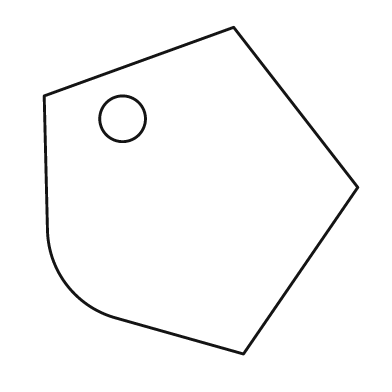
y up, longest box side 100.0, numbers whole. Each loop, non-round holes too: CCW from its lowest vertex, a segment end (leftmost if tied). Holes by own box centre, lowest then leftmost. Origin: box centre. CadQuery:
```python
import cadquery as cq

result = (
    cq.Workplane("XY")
    .moveTo(13.0, -50.0)
    .lineTo(48.0, 1.0)
    .lineTo(10.0, 50.0)
    .lineTo(-48.0, 29.0)
    .lineTo(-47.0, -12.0)
    .threePointArc((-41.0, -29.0), (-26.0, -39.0))
    .close()
    .moveTo(-24.0, 22.0)
    .circle(7.0)
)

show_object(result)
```